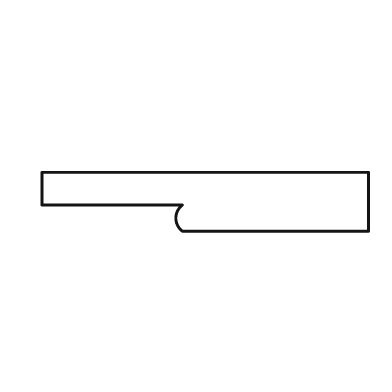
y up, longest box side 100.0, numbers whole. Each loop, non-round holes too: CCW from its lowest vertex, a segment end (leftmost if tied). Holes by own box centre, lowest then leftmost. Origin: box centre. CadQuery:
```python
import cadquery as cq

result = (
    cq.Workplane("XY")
    .moveTo(-7.0, -9.0)
    .lineTo(50.0, -9.0)
    .lineTo(50.0, 9.0)
    .lineTo(-50.0, 9.0)
    .lineTo(-50.0, -1.0)
    .lineTo(-7.0, -1.0)
    .threePointArc((-9.0, -5.0), (-7.0, -9.0))
    .close()
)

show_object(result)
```